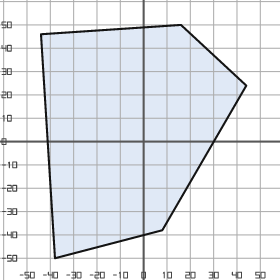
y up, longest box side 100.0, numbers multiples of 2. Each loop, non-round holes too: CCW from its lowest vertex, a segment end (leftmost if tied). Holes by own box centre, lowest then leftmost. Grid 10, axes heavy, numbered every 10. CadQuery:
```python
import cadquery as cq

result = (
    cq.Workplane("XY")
    .moveTo(-38.0, -50.0)
    .lineTo(8.0, -38.0)
    .lineTo(44.0, 24.0)
    .lineTo(16.0, 50.0)
    .lineTo(-44.0, 46.0)
    .close()
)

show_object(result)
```